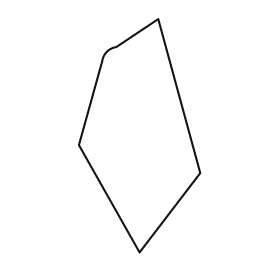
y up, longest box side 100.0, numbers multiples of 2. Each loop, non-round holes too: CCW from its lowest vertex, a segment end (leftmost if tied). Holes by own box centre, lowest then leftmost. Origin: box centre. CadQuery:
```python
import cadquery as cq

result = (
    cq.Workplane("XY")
    .moveTo(0.0, -50.0)
    .lineTo(26.0, -16.0)
    .lineTo(8.0, 50.0)
    .lineTo(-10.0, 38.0)
    .threePointArc((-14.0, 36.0), (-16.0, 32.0))
    .lineTo(-26.0, -4.0)
    .close()
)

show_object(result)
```